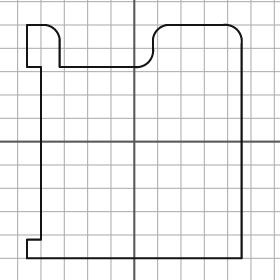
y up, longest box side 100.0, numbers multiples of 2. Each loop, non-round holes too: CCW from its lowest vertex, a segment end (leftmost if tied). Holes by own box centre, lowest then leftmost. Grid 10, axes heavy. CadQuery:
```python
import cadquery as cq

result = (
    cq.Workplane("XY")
    .moveTo(-46.0, -50.0)
    .lineTo(46.0, -50.0)
    .lineTo(46.0, 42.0)
    .threePointArc((44.0, 48.0), (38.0, 50.0))
    .lineTo(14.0, 50.0)
    .threePointArc((10.0, 48.0), (8.0, 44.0))
    .lineTo(8.0, 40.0)
    .threePointArc((6.0, 34.0), (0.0, 32.0))
    .lineTo(-32.0, 32.0)
    .lineTo(-32.0, 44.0)
    .threePointArc((-34.0, 48.0), (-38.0, 50.0))
    .lineTo(-46.0, 50.0)
    .lineTo(-46.0, 32.0)
    .lineTo(-40.0, 32.0)
    .lineTo(-40.0, -42.0)
    .lineTo(-46.0, -42.0)
    .close()
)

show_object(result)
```